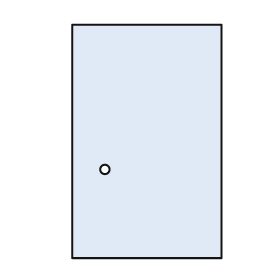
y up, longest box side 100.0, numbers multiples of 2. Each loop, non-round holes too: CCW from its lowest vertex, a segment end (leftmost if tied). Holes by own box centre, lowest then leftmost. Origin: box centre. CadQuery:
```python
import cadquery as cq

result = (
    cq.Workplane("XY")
    .moveTo(-32.0, -50.0)
    .lineTo(32.0, -50.0)
    .lineTo(32.0, 50.0)
    .lineTo(-32.0, 50.0)
    .close()
    .moveTo(-18.0, -12.0)
    .circle(2.0)
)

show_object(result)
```